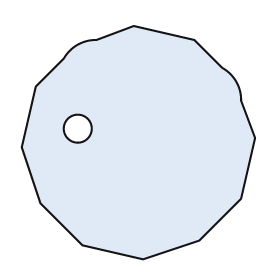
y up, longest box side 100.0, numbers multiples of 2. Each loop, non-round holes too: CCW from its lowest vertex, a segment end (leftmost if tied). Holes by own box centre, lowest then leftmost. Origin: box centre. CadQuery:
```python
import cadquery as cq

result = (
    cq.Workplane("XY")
    .moveTo(2.0, -50.0)
    .lineTo(26.0, -42.0)
    .lineTo(44.0, -24.0)
    .lineTo(50.0, 2.0)
    .lineTo(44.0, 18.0)
    .threePointArc((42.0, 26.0), (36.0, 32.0))
    .lineTo(24.0, 44.0)
    .lineTo(-2.0, 50.0)
    .lineTo(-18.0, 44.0)
    .threePointArc((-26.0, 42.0), (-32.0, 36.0))
    .lineTo(-44.0, 24.0)
    .lineTo(-50.0, -2.0)
    .lineTo(-42.0, -26.0)
    .lineTo(-24.0, -44.0)
    .close()
    .moveTo(-26.0, 6.0)
    .circle(6.0)
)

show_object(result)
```